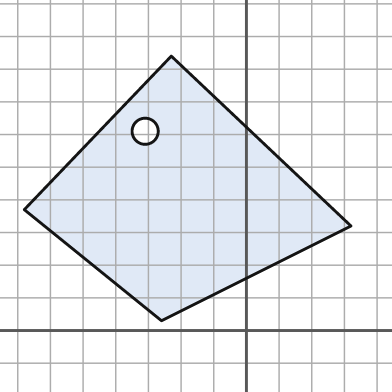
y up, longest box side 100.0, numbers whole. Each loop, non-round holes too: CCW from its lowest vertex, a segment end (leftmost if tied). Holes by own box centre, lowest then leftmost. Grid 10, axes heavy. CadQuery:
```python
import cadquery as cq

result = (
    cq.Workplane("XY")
    .moveTo(-26.0, 3.0)
    .lineTo(32.0, 32.0)
    .lineTo(-23.0, 84.0)
    .lineTo(-68.0, 37.0)
    .close()
    .moveTo(-31.0, 61.0)
    .circle(4.0)
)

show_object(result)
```